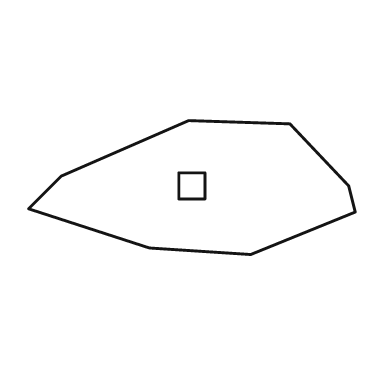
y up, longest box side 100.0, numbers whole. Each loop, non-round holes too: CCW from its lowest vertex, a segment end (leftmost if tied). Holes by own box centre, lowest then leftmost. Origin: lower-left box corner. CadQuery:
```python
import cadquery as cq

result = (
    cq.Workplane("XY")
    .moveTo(68.0, 0.0)
    .lineTo(100.0, 13.0)
    .lineTo(98.0, 21.0)
    .lineTo(80.0, 40.0)
    .lineTo(49.0, 41.0)
    .lineTo(10.0, 24.0)
    .lineTo(0.0, 14.0)
    .lineTo(37.0, 2.0)
    .close()
    .moveTo(46.0, 17.0)
    .lineTo(54.0, 17.0)
    .lineTo(54.0, 25.0)
    .lineTo(46.0, 25.0)
    .close()
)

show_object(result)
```